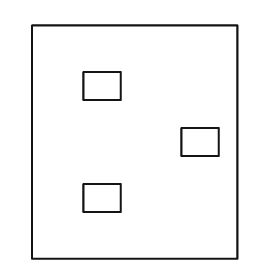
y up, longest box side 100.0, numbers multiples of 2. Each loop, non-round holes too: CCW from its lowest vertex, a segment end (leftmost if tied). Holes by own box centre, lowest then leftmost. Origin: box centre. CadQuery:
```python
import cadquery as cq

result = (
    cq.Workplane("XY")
    .moveTo(-44.0, -50.0)
    .lineTo(44.0, -50.0)
    .lineTo(44.0, 50.0)
    .lineTo(-44.0, 50.0)
    .close()
    .moveTo(-22.0, -30.0)
    .lineTo(-6.0, -30.0)
    .lineTo(-6.0, -18.0)
    .lineTo(-22.0, -18.0)
    .close()
    .moveTo(20.0, -6.0)
    .lineTo(36.0, -6.0)
    .lineTo(36.0, 6.0)
    .lineTo(20.0, 6.0)
    .close()
    .moveTo(-22.0, 18.0)
    .lineTo(-6.0, 18.0)
    .lineTo(-6.0, 30.0)
    .lineTo(-22.0, 30.0)
    .close()
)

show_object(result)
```